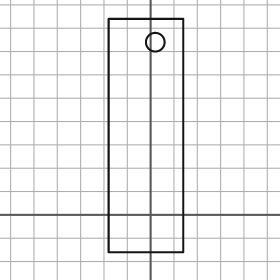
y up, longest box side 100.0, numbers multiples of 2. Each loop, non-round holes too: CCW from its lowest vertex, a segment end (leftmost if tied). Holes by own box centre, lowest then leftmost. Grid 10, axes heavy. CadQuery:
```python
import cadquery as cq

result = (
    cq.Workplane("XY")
    .moveTo(-18.0, -16.0)
    .lineTo(14.0, -16.0)
    .lineTo(14.0, 84.0)
    .lineTo(-18.0, 84.0)
    .close()
    .moveTo(2.0, 74.0)
    .circle(4.0)
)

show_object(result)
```